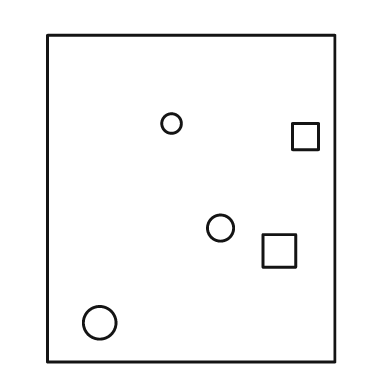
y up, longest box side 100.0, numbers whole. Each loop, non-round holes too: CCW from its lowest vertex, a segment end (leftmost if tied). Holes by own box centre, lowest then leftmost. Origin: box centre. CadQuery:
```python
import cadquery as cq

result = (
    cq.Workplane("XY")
    .moveTo(-44.0, -50.0)
    .lineTo(44.0, -50.0)
    .lineTo(44.0, 50.0)
    .lineTo(-44.0, 50.0)
    .close()
    .moveTo(-28.0, -38.0)
    .circle(5.0)
    .moveTo(22.0, -21.0)
    .lineTo(32.0, -21.0)
    .lineTo(32.0, -11.0)
    .lineTo(22.0, -11.0)
    .close()
    .moveTo(9.0, -9.0)
    .circle(4.0)
    .moveTo(31.0, 15.0)
    .lineTo(39.0, 15.0)
    .lineTo(39.0, 23.0)
    .lineTo(31.0, 23.0)
    .close()
    .moveTo(-6.0, 23.0)
    .circle(3.0)
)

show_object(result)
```